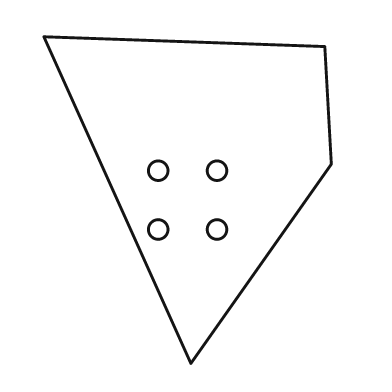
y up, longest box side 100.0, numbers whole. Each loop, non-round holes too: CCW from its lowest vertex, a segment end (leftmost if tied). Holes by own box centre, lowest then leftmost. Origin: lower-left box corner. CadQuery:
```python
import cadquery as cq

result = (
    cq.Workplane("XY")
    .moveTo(45.0, 0.0)
    .lineTo(88.0, 61.0)
    .lineTo(86.0, 97.0)
    .lineTo(0.0, 100.0)
    .close()
    .moveTo(35.0, 41.0)
    .circle(3.0)
    .moveTo(53.0, 41.0)
    .circle(3.0)
    .moveTo(35.0, 59.0)
    .circle(3.0)
    .moveTo(53.0, 59.0)
    .circle(3.0)
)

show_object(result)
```